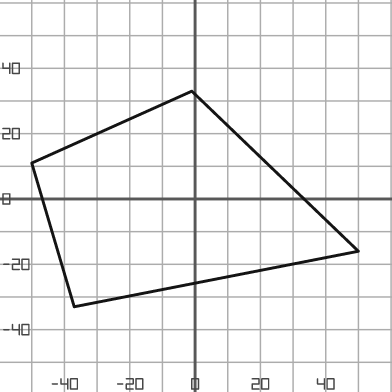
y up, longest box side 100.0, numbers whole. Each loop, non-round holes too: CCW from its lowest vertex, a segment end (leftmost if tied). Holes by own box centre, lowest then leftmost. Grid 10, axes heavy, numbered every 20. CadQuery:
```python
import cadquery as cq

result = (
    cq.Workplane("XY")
    .moveTo(-37.0, -33.0)
    .lineTo(50.0, -16.0)
    .lineTo(-1.0, 33.0)
    .lineTo(-50.0, 11.0)
    .close()
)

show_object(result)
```